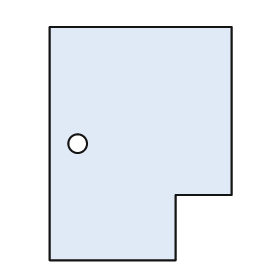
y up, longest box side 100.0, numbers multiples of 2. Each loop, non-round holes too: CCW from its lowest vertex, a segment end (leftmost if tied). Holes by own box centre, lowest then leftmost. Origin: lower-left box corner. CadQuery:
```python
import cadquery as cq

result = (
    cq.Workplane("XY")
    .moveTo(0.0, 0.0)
    .lineTo(54.0, 0.0)
    .lineTo(54.0, 28.0)
    .lineTo(78.0, 28.0)
    .lineTo(78.0, 100.0)
    .lineTo(0.0, 100.0)
    .close()
    .moveTo(12.0, 50.0)
    .circle(4.0)
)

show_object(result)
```